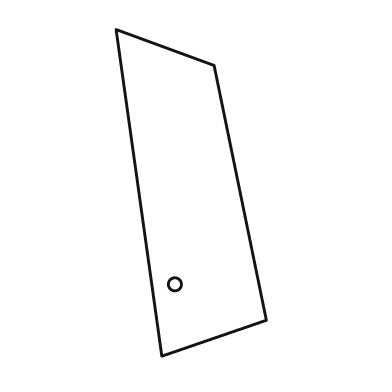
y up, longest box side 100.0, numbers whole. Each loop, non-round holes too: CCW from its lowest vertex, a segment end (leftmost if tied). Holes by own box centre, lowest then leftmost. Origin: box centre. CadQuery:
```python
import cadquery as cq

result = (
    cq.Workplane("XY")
    .moveTo(-9.0, -50.0)
    .lineTo(23.0, -39.0)
    .lineTo(7.0, 39.0)
    .lineTo(-23.0, 50.0)
    .close()
    .moveTo(-5.0, -28.0)
    .circle(2.0)
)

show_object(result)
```